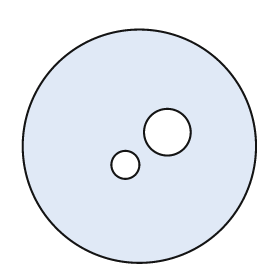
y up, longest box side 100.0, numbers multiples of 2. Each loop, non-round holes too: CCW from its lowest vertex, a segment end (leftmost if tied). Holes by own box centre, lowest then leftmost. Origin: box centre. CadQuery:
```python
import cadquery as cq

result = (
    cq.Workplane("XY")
    .moveTo(0.0, 0.0)
    .circle(50.0)
    .moveTo(-6.0, -8.0)
    .circle(6.0)
    .moveTo(12.0, 6.0)
    .circle(10.0)
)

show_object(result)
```